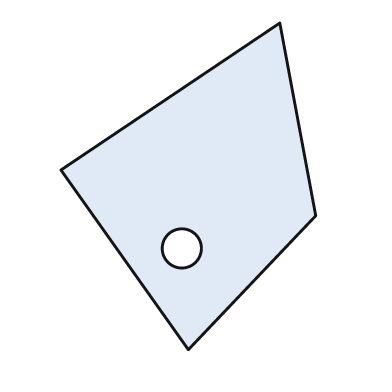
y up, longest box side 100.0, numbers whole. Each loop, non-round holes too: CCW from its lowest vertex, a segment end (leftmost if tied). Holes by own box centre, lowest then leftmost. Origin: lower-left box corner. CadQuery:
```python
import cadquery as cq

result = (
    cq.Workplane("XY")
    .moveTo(39.0, 0.0)
    .lineTo(78.0, 41.0)
    .lineTo(67.0, 100.0)
    .lineTo(0.0, 55.0)
    .close()
    .moveTo(37.0, 31.0)
    .circle(6.0)
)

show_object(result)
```